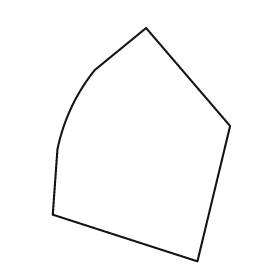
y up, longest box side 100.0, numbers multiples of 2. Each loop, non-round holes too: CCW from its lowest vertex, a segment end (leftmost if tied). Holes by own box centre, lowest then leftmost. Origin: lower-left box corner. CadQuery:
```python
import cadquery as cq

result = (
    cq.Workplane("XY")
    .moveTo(62.0, 0.0)
    .lineTo(76.0, 58.0)
    .lineTo(40.0, 100.0)
    .lineTo(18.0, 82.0)
    .threePointArc((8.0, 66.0), (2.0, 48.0))
    .lineTo(0.0, 20.0)
    .close()
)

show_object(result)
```